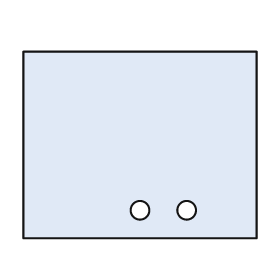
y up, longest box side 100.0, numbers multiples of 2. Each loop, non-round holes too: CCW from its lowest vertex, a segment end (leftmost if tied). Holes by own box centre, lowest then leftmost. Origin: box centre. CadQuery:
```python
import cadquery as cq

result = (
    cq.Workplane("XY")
    .moveTo(-50.0, -40.0)
    .lineTo(50.0, -40.0)
    .lineTo(50.0, 40.0)
    .lineTo(-50.0, 40.0)
    .close()
    .moveTo(0.0, -28.0)
    .circle(4.0)
    .moveTo(20.0, -28.0)
    .circle(4.0)
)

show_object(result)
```